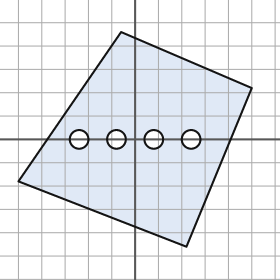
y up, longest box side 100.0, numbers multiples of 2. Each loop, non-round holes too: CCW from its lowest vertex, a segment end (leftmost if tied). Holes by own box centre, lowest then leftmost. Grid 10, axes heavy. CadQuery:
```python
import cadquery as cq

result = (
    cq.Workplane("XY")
    .moveTo(22.0, -46.0)
    .lineTo(50.0, 22.0)
    .lineTo(-6.0, 46.0)
    .lineTo(-50.0, -18.0)
    .close()
    .moveTo(-24.0, 0.0)
    .circle(4.0)
    .moveTo(-8.0, 0.0)
    .circle(4.0)
    .moveTo(8.0, 0.0)
    .circle(4.0)
    .moveTo(24.0, 0.0)
    .circle(4.0)
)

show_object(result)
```